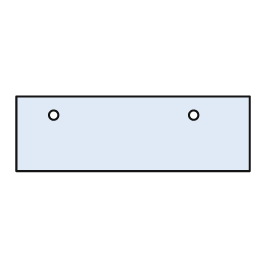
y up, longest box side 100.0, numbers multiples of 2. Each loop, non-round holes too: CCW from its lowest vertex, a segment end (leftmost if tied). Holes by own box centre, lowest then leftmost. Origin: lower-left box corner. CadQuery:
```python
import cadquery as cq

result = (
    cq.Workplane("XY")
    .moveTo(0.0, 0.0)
    .lineTo(100.0, 0.0)
    .lineTo(100.0, 32.0)
    .lineTo(0.0, 32.0)
    .close()
    .moveTo(16.0, 24.0)
    .circle(2.0)
    .moveTo(76.0, 24.0)
    .circle(2.0)
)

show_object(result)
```